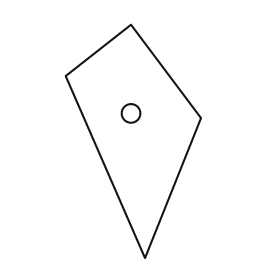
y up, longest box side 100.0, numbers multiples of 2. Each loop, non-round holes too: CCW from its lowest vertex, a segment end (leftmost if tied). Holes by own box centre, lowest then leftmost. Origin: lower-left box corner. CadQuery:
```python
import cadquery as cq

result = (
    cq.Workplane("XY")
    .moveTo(34.0, 0.0)
    .lineTo(58.0, 60.0)
    .lineTo(28.0, 100.0)
    .lineTo(0.0, 78.0)
    .close()
    .moveTo(28.0, 62.0)
    .circle(4.0)
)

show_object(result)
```